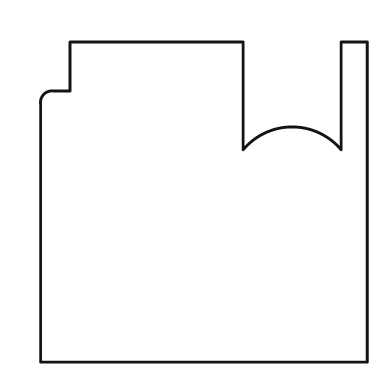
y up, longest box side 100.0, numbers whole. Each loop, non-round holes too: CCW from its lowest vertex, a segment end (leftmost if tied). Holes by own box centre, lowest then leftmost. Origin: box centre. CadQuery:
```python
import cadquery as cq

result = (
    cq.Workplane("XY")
    .moveTo(-50.0, -49.0)
    .lineTo(50.0, -49.0)
    .lineTo(50.0, 49.0)
    .lineTo(42.0, 49.0)
    .lineTo(42.0, 16.0)
    .threePointArc((27.0, 23.0), (12.0, 16.0))
    .lineTo(12.0, 49.0)
    .lineTo(-41.0, 49.0)
    .lineTo(-41.0, 34.0)
    .lineTo(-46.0, 34.0)
    .threePointArc((-49.0, 33.0), (-50.0, 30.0))
    .close()
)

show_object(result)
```